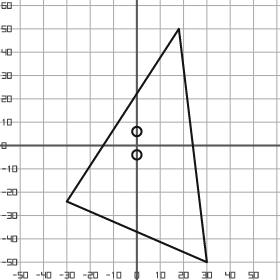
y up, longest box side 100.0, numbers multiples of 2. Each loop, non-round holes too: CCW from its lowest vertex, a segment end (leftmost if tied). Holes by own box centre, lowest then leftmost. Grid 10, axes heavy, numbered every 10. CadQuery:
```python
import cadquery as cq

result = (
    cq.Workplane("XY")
    .moveTo(30.0, -50.0)
    .lineTo(18.0, 50.0)
    .lineTo(-30.0, -24.0)
    .close()
    .moveTo(0.0, -4.0)
    .circle(2.0)
    .moveTo(0.0, 6.0)
    .circle(2.0)
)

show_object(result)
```